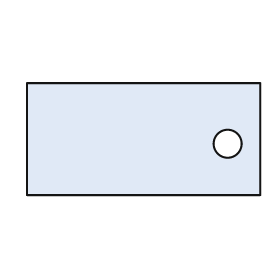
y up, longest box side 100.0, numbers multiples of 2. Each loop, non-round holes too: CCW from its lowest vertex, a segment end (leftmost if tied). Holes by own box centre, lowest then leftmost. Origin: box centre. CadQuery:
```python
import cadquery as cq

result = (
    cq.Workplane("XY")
    .moveTo(-50.0, -24.0)
    .lineTo(50.0, -24.0)
    .lineTo(50.0, 24.0)
    .lineTo(-50.0, 24.0)
    .close()
    .moveTo(36.0, -2.0)
    .circle(6.0)
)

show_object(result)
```